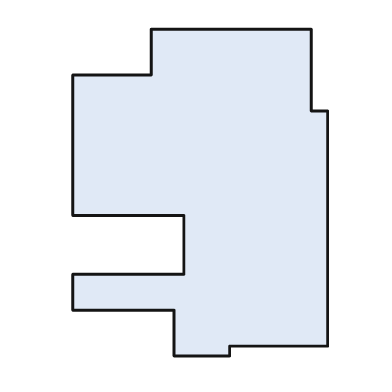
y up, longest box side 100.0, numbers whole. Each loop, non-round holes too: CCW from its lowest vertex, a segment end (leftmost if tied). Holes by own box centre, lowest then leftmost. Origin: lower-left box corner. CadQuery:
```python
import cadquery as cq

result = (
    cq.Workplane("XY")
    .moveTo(31.0, 0.0)
    .lineTo(48.0, 0.0)
    .lineTo(48.0, 3.0)
    .lineTo(78.0, 3.0)
    .lineTo(78.0, 75.0)
    .lineTo(73.0, 75.0)
    .lineTo(73.0, 100.0)
    .lineTo(24.0, 100.0)
    .lineTo(24.0, 86.0)
    .lineTo(0.0, 86.0)
    .lineTo(0.0, 43.0)
    .lineTo(34.0, 43.0)
    .lineTo(34.0, 25.0)
    .lineTo(0.0, 25.0)
    .lineTo(0.0, 14.0)
    .lineTo(31.0, 14.0)
    .close()
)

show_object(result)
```